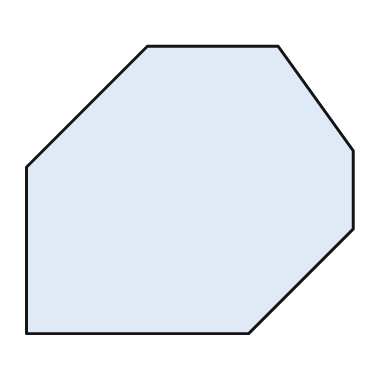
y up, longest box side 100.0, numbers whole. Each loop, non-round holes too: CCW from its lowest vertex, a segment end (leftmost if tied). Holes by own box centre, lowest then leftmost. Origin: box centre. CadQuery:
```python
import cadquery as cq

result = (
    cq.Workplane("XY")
    .moveTo(-50.0, -44.0)
    .lineTo(18.0, -44.0)
    .lineTo(50.0, -12.0)
    .lineTo(50.0, 12.0)
    .lineTo(27.0, 44.0)
    .lineTo(-13.0, 44.0)
    .lineTo(-50.0, 7.0)
    .close()
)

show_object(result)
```